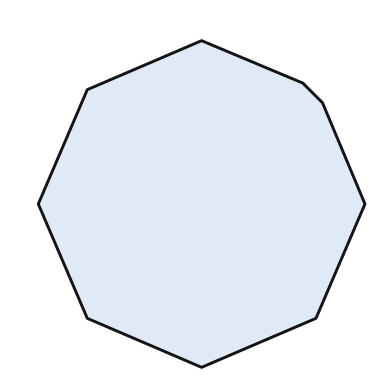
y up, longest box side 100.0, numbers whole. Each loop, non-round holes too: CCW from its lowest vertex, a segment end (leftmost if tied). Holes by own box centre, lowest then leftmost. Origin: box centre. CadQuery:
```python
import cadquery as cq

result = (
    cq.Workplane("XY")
    .moveTo(0.0, -50.0)
    .lineTo(35.0, -35.0)
    .lineTo(50.0, 0.0)
    .lineTo(37.0, 31.0)
    .lineTo(31.0, 37.0)
    .lineTo(0.0, 50.0)
    .lineTo(-35.0, 35.0)
    .lineTo(-50.0, 0.0)
    .lineTo(-35.0, -35.0)
    .close()
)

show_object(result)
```